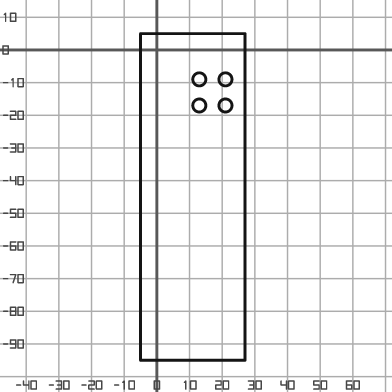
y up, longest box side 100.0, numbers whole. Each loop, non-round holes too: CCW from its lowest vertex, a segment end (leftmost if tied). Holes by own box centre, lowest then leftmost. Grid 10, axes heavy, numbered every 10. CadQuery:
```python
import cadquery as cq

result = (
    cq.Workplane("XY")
    .moveTo(-5.0, -95.0)
    .lineTo(27.0, -95.0)
    .lineTo(27.0, 5.0)
    .lineTo(-5.0, 5.0)
    .close()
    .moveTo(13.0, -17.0)
    .circle(2.0)
    .moveTo(21.0, -17.0)
    .circle(2.0)
    .moveTo(13.0, -9.0)
    .circle(2.0)
    .moveTo(21.0, -9.0)
    .circle(2.0)
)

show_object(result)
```